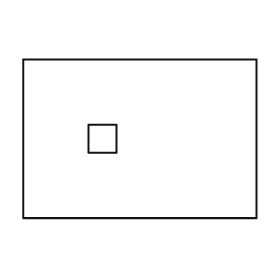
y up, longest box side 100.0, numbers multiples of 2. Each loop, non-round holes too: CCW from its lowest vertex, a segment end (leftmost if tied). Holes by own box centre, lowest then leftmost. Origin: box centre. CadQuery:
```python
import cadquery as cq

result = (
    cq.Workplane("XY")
    .moveTo(-50.0, -34.0)
    .lineTo(50.0, -34.0)
    .lineTo(50.0, 34.0)
    .lineTo(-50.0, 34.0)
    .close()
    .moveTo(-22.0, -6.0)
    .lineTo(-10.0, -6.0)
    .lineTo(-10.0, 6.0)
    .lineTo(-22.0, 6.0)
    .close()
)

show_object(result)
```